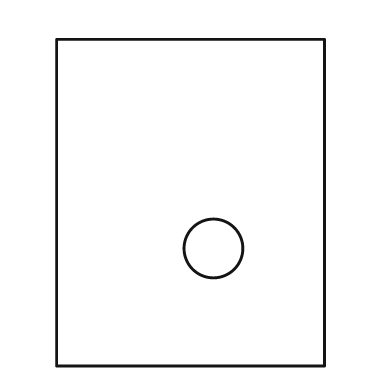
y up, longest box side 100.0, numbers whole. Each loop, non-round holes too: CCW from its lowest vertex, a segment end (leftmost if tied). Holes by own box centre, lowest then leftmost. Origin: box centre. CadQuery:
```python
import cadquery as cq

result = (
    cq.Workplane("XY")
    .moveTo(-41.0, -50.0)
    .lineTo(41.0, -50.0)
    .lineTo(41.0, 50.0)
    .lineTo(-41.0, 50.0)
    .close()
    .moveTo(7.0, -14.0)
    .circle(9.0)
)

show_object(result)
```